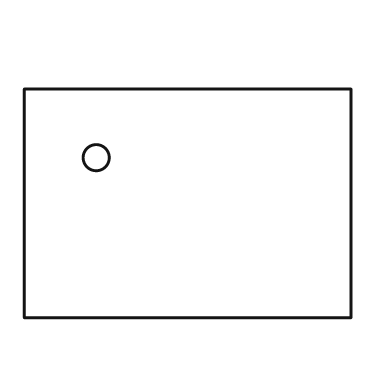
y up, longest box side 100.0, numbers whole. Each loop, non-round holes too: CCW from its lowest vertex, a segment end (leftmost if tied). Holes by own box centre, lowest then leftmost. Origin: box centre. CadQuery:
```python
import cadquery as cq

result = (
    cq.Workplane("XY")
    .moveTo(-50.0, -35.0)
    .lineTo(50.0, -35.0)
    .lineTo(50.0, 35.0)
    .lineTo(-50.0, 35.0)
    .close()
    .moveTo(-28.0, 14.0)
    .circle(4.0)
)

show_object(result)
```